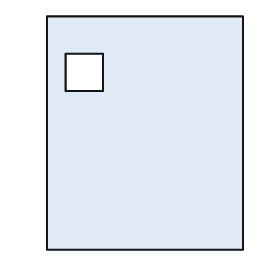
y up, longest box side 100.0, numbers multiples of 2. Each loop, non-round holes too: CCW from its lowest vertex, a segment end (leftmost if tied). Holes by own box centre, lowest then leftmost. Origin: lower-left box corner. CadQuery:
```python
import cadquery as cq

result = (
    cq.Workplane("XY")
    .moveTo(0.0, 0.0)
    .lineTo(84.0, 0.0)
    .lineTo(84.0, 100.0)
    .lineTo(0.0, 100.0)
    .close()
    .moveTo(8.0, 68.0)
    .lineTo(24.0, 68.0)
    .lineTo(24.0, 84.0)
    .lineTo(8.0, 84.0)
    .close()
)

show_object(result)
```